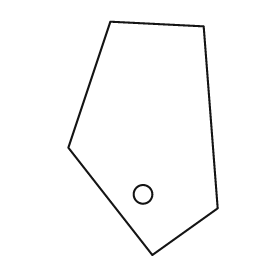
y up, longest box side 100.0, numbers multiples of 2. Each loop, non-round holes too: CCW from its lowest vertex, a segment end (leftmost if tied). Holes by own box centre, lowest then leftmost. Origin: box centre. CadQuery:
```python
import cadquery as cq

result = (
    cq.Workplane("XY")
    .moveTo(4.0, -50.0)
    .lineTo(32.0, -30.0)
    .lineTo(26.0, 48.0)
    .lineTo(-14.0, 50.0)
    .lineTo(-32.0, -4.0)
    .close()
    .moveTo(0.0, -24.0)
    .circle(4.0)
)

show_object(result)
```